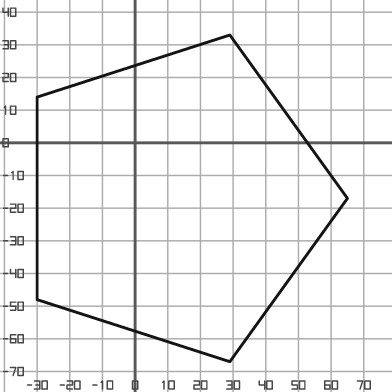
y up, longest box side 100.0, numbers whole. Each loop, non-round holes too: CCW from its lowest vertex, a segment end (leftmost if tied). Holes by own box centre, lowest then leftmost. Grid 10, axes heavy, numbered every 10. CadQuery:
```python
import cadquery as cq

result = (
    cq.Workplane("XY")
    .moveTo(29.0, -67.0)
    .lineTo(65.0, -17.0)
    .lineTo(29.0, 33.0)
    .lineTo(-30.0, 14.0)
    .lineTo(-30.0, -48.0)
    .close()
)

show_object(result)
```